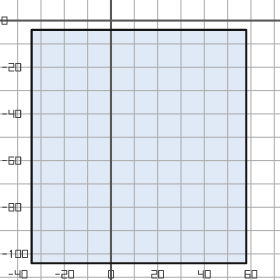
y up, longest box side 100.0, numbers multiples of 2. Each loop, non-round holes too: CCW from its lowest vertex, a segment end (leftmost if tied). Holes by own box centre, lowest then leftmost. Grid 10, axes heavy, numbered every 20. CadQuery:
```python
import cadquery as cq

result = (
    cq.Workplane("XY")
    .moveTo(-34.0, -104.0)
    .lineTo(58.0, -104.0)
    .lineTo(58.0, -4.0)
    .lineTo(-34.0, -4.0)
    .close()
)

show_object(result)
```